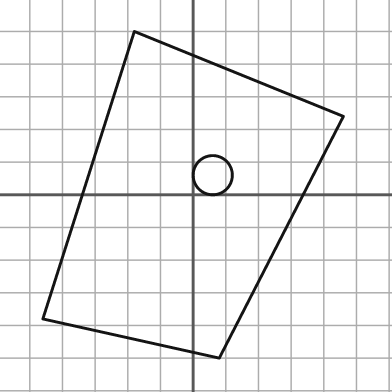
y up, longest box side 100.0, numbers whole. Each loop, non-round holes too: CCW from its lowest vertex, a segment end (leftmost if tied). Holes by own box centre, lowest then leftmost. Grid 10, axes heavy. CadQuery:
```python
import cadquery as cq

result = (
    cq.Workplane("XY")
    .moveTo(8.0, -50.0)
    .lineTo(46.0, 24.0)
    .lineTo(-18.0, 50.0)
    .lineTo(-46.0, -38.0)
    .close()
    .moveTo(6.0, 6.0)
    .circle(6.0)
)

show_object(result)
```